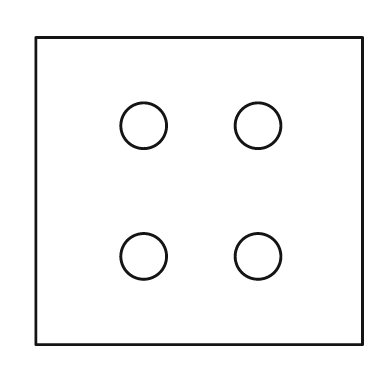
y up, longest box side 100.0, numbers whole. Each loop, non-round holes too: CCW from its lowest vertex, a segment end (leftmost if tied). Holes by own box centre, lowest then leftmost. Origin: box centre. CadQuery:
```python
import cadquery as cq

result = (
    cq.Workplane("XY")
    .moveTo(-50.0, -47.0)
    .lineTo(50.0, -47.0)
    .lineTo(50.0, 47.0)
    .lineTo(-50.0, 47.0)
    .close()
    .moveTo(-17.0, -20.0)
    .circle(7.0)
    .moveTo(18.0, -20.0)
    .circle(7.0)
    .moveTo(-17.0, 20.0)
    .circle(7.0)
    .moveTo(18.0, 20.0)
    .circle(7.0)
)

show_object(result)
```